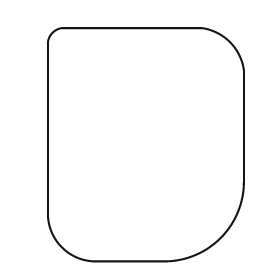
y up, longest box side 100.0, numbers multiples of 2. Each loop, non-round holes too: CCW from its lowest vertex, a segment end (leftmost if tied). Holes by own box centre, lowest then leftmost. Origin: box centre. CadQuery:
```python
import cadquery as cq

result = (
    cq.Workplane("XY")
    .moveTo(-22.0, -50.0)
    .lineTo(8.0, -50.0)
    .threePointArc((32.0, -40.0), (42.0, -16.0))
    .lineTo(42.0, 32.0)
    .threePointArc((36.0, 44.0), (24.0, 50.0))
    .lineTo(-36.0, 50.0)
    .threePointArc((-40.0, 48.0), (-42.0, 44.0))
    .lineTo(-42.0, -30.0)
    .threePointArc((-36.0, -44.0), (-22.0, -50.0))
    .close()
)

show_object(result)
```